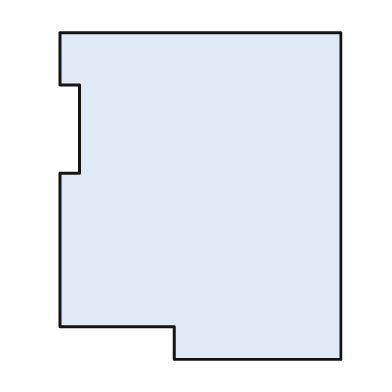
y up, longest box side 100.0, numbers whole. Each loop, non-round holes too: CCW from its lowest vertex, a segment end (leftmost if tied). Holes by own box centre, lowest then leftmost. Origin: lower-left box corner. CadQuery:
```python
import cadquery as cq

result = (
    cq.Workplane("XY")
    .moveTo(35.0, 0.0)
    .lineTo(86.0, 0.0)
    .lineTo(86.0, 100.0)
    .lineTo(0.0, 100.0)
    .lineTo(0.0, 84.0)
    .lineTo(6.0, 84.0)
    .lineTo(6.0, 57.0)
    .lineTo(0.0, 57.0)
    .lineTo(0.0, 10.0)
    .lineTo(35.0, 10.0)
    .close()
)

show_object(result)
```